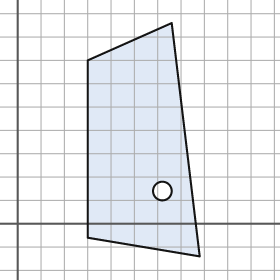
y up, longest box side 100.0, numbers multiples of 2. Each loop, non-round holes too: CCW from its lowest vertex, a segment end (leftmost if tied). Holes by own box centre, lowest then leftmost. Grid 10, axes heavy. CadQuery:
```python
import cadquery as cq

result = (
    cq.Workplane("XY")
    .moveTo(78.0, -14.0)
    .lineTo(66.0, 86.0)
    .lineTo(30.0, 70.0)
    .lineTo(30.0, -6.0)
    .close()
    .moveTo(62.0, 14.0)
    .circle(4.0)
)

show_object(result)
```